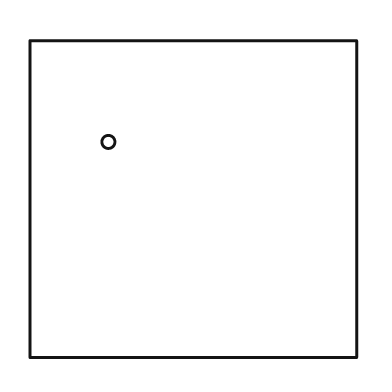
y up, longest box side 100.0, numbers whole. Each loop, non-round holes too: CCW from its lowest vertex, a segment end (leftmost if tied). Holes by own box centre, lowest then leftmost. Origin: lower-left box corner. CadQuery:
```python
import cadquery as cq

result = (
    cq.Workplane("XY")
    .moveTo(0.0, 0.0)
    .lineTo(100.0, 0.0)
    .lineTo(100.0, 97.0)
    .lineTo(0.0, 97.0)
    .close()
    .moveTo(24.0, 66.0)
    .circle(2.0)
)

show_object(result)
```